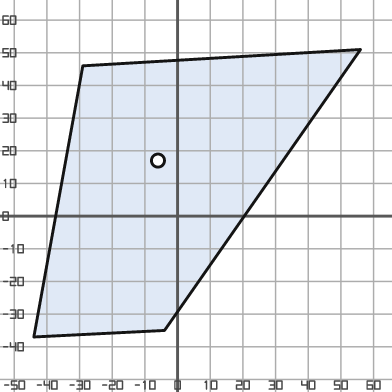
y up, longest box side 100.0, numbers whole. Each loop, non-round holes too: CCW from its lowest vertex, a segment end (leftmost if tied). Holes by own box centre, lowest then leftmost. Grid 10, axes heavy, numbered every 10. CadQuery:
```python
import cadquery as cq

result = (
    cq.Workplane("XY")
    .moveTo(-44.0, -37.0)
    .lineTo(-4.0, -35.0)
    .lineTo(56.0, 51.0)
    .lineTo(-29.0, 46.0)
    .close()
    .moveTo(-6.0, 17.0)
    .circle(2.0)
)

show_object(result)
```